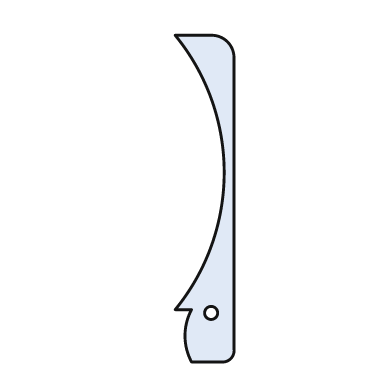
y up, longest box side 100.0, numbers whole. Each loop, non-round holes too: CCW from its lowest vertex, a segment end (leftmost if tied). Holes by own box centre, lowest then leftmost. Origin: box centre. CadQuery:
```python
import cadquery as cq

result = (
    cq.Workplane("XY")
    .moveTo(-4.0, -50.0)
    .lineTo(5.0, -50.0)
    .threePointArc((8.0, -49.0), (9.0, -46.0))
    .lineTo(9.0, 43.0)
    .threePointArc((7.0, 48.0), (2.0, 50.0))
    .lineTo(-9.0, 50.0)
    .threePointArc((6.0, 8.0), (-9.0, -34.0))
    .lineTo(-4.0, -34.0)
    .threePointArc((-6.0, -42.0), (-4.0, -50.0))
    .close()
    .moveTo(2.0, -35.0)
    .circle(2.0)
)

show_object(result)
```